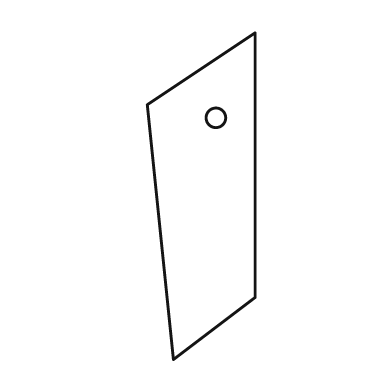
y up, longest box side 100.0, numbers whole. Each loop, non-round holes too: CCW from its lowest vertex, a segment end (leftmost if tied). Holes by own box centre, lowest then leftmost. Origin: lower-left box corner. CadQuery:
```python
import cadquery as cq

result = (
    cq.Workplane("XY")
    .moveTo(8.0, 0.0)
    .lineTo(33.0, 19.0)
    .lineTo(33.0, 100.0)
    .lineTo(0.0, 78.0)
    .close()
    .moveTo(21.0, 74.0)
    .circle(3.0)
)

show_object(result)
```